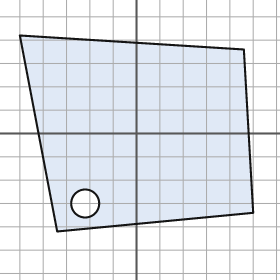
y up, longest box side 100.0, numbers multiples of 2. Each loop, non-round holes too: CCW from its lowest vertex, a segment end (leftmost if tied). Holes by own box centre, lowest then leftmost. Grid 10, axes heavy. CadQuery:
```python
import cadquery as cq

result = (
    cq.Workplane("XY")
    .moveTo(-34.0, -42.0)
    .lineTo(50.0, -34.0)
    .lineTo(46.0, 36.0)
    .lineTo(-50.0, 42.0)
    .close()
    .moveTo(-22.0, -30.0)
    .circle(6.0)
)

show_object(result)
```